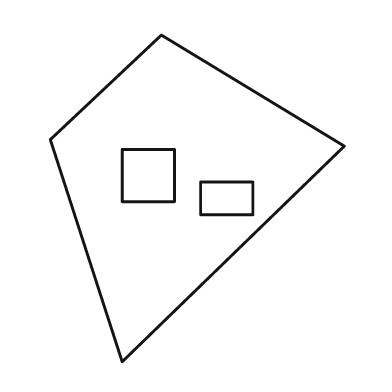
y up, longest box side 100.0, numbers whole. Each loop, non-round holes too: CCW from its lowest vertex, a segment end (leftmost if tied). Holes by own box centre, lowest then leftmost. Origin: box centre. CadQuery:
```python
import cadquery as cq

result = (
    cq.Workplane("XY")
    .moveTo(-23.0, -50.0)
    .lineTo(45.0, 16.0)
    .lineTo(-11.0, 50.0)
    .lineTo(-45.0, 18.0)
    .close()
    .moveTo(1.0, -5.0)
    .lineTo(17.0, -5.0)
    .lineTo(17.0, 5.0)
    .lineTo(1.0, 5.0)
    .close()
    .moveTo(-23.0, -1.0)
    .lineTo(-7.0, -1.0)
    .lineTo(-7.0, 15.0)
    .lineTo(-23.0, 15.0)
    .close()
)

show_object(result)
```